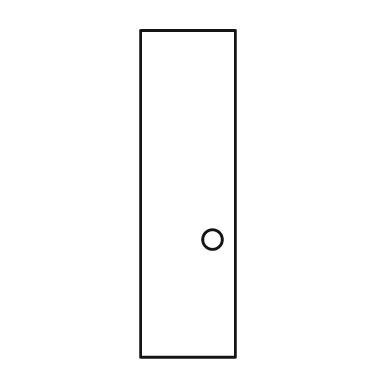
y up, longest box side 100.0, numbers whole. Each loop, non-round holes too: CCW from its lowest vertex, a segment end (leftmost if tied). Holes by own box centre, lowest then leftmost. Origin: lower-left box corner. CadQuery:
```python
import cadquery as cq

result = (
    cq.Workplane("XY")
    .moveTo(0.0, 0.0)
    .lineTo(29.0, 0.0)
    .lineTo(29.0, 100.0)
    .lineTo(0.0, 100.0)
    .close()
    .moveTo(22.0, 36.0)
    .circle(3.0)
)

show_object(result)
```